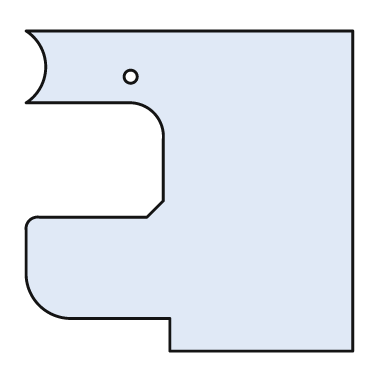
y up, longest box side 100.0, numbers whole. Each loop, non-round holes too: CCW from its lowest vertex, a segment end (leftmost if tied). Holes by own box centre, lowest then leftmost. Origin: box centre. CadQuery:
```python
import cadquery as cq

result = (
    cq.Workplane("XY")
    .moveTo(-6.0, -49.0)
    .lineTo(50.0, -49.0)
    .lineTo(50.0, 49.0)
    .lineTo(-50.0, 49.0)
    .threePointArc((-44.0, 38.0), (-50.0, 27.0))
    .lineTo(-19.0, 27.0)
    .threePointArc((-11.0, 24.0), (-8.0, 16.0))
    .lineTo(-8.0, -3.0)
    .lineTo(-13.0, -8.0)
    .lineTo(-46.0, -8.0)
    .threePointArc((-49.0, -9.0), (-50.0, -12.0))
    .lineTo(-50.0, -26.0)
    .threePointArc((-46.0, -35.0), (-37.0, -39.0))
    .lineTo(-6.0, -39.0)
    .close()
    .moveTo(-18.0, 35.0)
    .circle(2.0)
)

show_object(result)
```